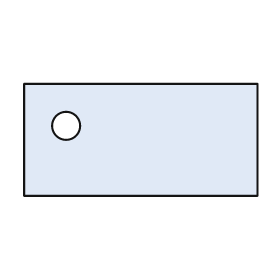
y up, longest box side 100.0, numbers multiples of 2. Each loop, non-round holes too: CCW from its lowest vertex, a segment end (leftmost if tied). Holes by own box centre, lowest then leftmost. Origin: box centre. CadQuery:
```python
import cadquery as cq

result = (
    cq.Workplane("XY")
    .moveTo(-50.0, -24.0)
    .lineTo(50.0, -24.0)
    .lineTo(50.0, 24.0)
    .lineTo(-50.0, 24.0)
    .close()
    .moveTo(-32.0, 6.0)
    .circle(6.0)
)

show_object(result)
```